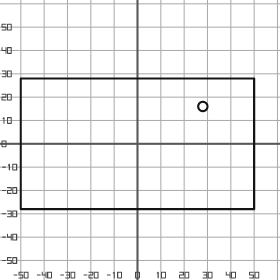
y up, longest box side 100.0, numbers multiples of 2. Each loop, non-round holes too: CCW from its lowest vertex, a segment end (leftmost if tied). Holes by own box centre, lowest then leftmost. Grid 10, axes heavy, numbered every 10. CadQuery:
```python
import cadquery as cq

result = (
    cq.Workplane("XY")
    .moveTo(-50.0, -28.0)
    .lineTo(50.0, -28.0)
    .lineTo(50.0, 28.0)
    .lineTo(-50.0, 28.0)
    .close()
    .moveTo(28.0, 16.0)
    .circle(2.0)
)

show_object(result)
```